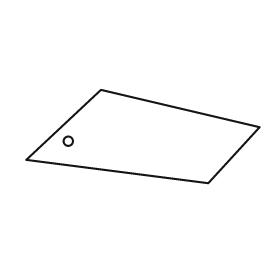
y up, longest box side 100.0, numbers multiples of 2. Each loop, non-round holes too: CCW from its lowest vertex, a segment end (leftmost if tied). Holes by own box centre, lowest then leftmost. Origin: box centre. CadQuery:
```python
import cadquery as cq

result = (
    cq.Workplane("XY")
    .moveTo(28.0, -20.0)
    .lineTo(50.0, 4.0)
    .lineTo(-18.0, 20.0)
    .lineTo(-50.0, -10.0)
    .close()
    .moveTo(-32.0, -2.0)
    .circle(2.0)
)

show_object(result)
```